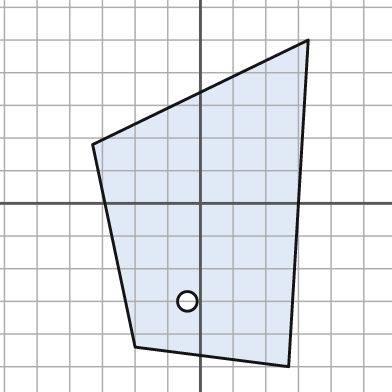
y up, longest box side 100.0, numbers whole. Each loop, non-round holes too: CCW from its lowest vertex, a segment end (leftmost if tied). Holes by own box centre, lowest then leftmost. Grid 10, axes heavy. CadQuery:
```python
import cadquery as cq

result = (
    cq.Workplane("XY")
    .moveTo(27.0, -50.0)
    .lineTo(33.0, 50.0)
    .lineTo(-33.0, 18.0)
    .lineTo(-20.0, -44.0)
    .close()
    .moveTo(-4.0, -30.0)
    .circle(3.0)
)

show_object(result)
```